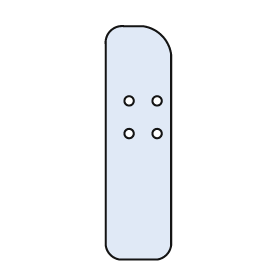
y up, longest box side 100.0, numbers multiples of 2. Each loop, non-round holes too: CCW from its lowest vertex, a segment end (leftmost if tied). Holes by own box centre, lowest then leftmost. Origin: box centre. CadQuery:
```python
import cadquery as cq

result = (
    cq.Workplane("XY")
    .moveTo(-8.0, -50.0)
    .lineTo(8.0, -50.0)
    .threePointArc((12.0, -48.0), (14.0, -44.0))
    .lineTo(14.0, 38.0)
    .threePointArc((10.0, 46.0), (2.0, 50.0))
    .lineTo(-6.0, 50.0)
    .threePointArc((-12.0, 48.0), (-14.0, 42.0))
    .lineTo(-14.0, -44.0)
    .threePointArc((-12.0, -48.0), (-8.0, -50.0))
    .close()
    .moveTo(-4.0, 4.0)
    .circle(2.0)
    .moveTo(8.0, 4.0)
    .circle(2.0)
    .moveTo(-4.0, 18.0)
    .circle(2.0)
    .moveTo(8.0, 18.0)
    .circle(2.0)
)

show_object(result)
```